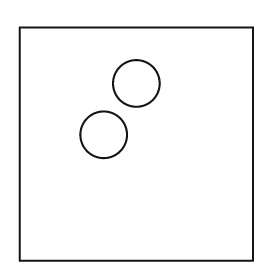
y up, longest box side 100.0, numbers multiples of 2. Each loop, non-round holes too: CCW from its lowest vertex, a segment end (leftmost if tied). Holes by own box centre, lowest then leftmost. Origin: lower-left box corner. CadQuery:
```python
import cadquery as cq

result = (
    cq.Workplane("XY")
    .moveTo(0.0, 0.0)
    .lineTo(100.0, 0.0)
    .lineTo(100.0, 100.0)
    .lineTo(0.0, 100.0)
    .close()
    .moveTo(36.0, 54.0)
    .circle(10.0)
    .moveTo(50.0, 76.0)
    .circle(10.0)
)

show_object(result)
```